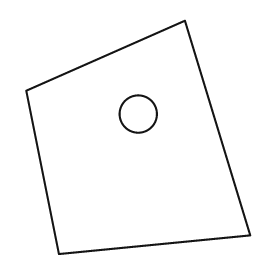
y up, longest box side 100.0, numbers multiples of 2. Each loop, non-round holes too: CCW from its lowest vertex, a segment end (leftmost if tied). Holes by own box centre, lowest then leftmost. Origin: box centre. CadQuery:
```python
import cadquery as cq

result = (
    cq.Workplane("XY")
    .moveTo(-34.0, -50.0)
    .lineTo(48.0, -42.0)
    .lineTo(20.0, 50.0)
    .lineTo(-48.0, 20.0)
    .close()
    .moveTo(0.0, 10.0)
    .circle(8.0)
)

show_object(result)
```